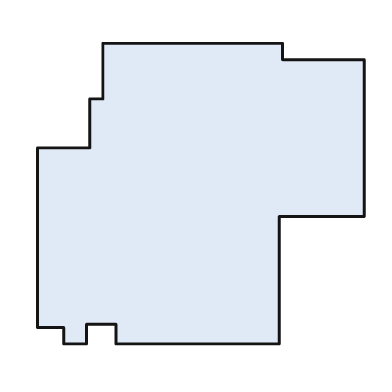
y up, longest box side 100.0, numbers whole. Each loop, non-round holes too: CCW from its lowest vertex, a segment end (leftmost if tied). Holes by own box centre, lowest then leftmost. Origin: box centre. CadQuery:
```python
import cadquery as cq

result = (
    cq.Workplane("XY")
    .moveTo(-42.0, -46.0)
    .lineTo(-35.0, -46.0)
    .lineTo(-35.0, -40.0)
    .lineTo(-26.0, -40.0)
    .lineTo(-26.0, -46.0)
    .lineTo(24.0, -46.0)
    .lineTo(24.0, -7.0)
    .lineTo(50.0, -7.0)
    .lineTo(50.0, 41.0)
    .lineTo(25.0, 41.0)
    .lineTo(25.0, 46.0)
    .lineTo(-30.0, 46.0)
    .lineTo(-30.0, 29.0)
    .lineTo(-34.0, 29.0)
    .lineTo(-34.0, 14.0)
    .lineTo(-50.0, 14.0)
    .lineTo(-50.0, -41.0)
    .lineTo(-42.0, -41.0)
    .close()
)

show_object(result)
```